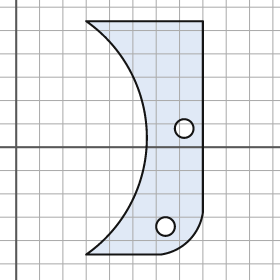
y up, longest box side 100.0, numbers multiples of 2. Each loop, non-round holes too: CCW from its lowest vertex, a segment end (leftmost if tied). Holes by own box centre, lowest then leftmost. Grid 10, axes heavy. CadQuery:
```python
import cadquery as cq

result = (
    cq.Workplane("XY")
    .moveTo(30.0, -46.0)
    .lineTo(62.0, -46.0)
    .threePointArc((74.0, -40.0), (80.0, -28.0))
    .lineTo(80.0, 54.0)
    .lineTo(30.0, 54.0)
    .threePointArc((56.0, 4.0), (30.0, -46.0))
    .close()
    .moveTo(64.0, -34.0)
    .circle(4.0)
    .moveTo(72.0, 8.0)
    .circle(4.0)
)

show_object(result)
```